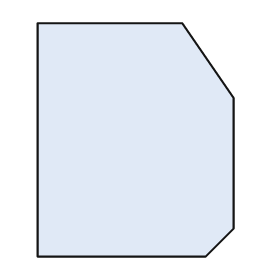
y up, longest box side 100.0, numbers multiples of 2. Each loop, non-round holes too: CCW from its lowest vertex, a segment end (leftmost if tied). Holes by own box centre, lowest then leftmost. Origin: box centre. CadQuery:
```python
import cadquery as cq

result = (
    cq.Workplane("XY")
    .moveTo(-42.0, -50.0)
    .lineTo(30.0, -50.0)
    .lineTo(42.0, -38.0)
    .lineTo(42.0, 18.0)
    .lineTo(20.0, 50.0)
    .lineTo(-42.0, 50.0)
    .close()
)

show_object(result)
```